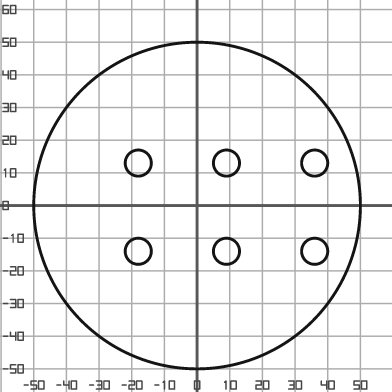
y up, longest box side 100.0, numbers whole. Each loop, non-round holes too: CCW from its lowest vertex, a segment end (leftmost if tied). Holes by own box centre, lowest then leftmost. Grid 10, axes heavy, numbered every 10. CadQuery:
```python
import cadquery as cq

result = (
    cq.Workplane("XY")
    .moveTo(0.0, 0.0)
    .circle(50.0)
    .moveTo(-18.0, -14.0)
    .circle(4.0)
    .moveTo(9.0, -14.0)
    .circle(4.0)
    .moveTo(36.0, -14.0)
    .circle(4.0)
    .moveTo(-18.0, 13.0)
    .circle(4.0)
    .moveTo(9.0, 13.0)
    .circle(4.0)
    .moveTo(36.0, 13.0)
    .circle(4.0)
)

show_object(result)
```